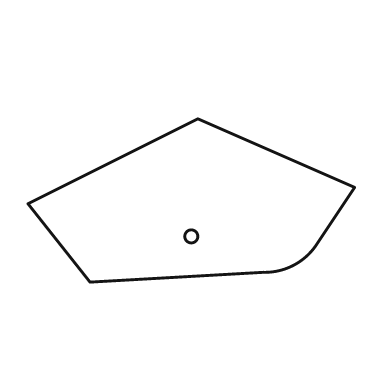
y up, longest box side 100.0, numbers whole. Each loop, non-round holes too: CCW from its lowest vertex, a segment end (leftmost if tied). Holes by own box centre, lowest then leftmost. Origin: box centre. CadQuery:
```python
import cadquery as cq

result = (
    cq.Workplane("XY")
    .moveTo(-31.0, -25.0)
    .lineTo(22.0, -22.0)
    .threePointArc((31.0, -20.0), (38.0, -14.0))
    .lineTo(50.0, 4.0)
    .lineTo(2.0, 25.0)
    .lineTo(-50.0, -1.0)
    .close()
    .moveTo(0.0, -11.0)
    .circle(2.0)
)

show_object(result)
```